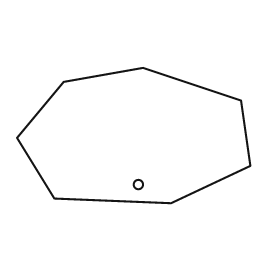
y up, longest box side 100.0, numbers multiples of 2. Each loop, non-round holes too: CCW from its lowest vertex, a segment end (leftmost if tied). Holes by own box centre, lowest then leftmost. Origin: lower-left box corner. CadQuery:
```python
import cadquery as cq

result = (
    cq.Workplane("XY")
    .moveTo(66.0, 0.0)
    .lineTo(100.0, 16.0)
    .lineTo(96.0, 44.0)
    .lineTo(54.0, 58.0)
    .lineTo(20.0, 52.0)
    .lineTo(0.0, 28.0)
    .lineTo(16.0, 2.0)
    .close()
    .moveTo(52.0, 8.0)
    .circle(2.0)
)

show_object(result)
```